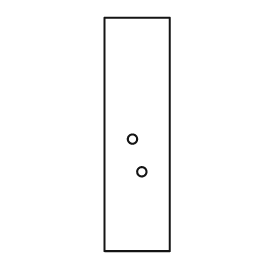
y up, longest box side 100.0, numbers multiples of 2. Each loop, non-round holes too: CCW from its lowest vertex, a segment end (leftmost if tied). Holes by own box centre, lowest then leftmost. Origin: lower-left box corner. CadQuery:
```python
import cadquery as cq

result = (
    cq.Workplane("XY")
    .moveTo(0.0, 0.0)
    .lineTo(28.0, 0.0)
    .lineTo(28.0, 100.0)
    .lineTo(0.0, 100.0)
    .close()
    .moveTo(16.0, 34.0)
    .circle(2.0)
    .moveTo(12.0, 48.0)
    .circle(2.0)
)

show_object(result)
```